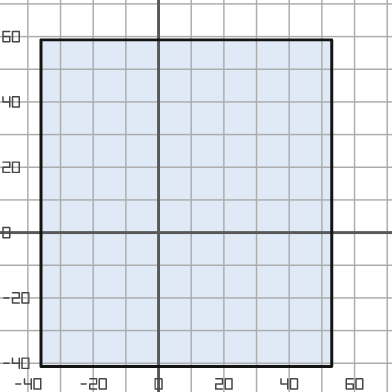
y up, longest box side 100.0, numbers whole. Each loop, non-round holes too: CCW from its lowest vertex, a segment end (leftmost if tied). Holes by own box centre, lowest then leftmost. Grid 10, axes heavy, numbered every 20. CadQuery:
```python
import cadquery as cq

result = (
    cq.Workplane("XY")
    .moveTo(-36.0, -41.0)
    .lineTo(53.0, -41.0)
    .lineTo(53.0, 59.0)
    .lineTo(-36.0, 59.0)
    .close()
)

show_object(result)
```